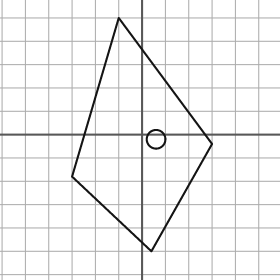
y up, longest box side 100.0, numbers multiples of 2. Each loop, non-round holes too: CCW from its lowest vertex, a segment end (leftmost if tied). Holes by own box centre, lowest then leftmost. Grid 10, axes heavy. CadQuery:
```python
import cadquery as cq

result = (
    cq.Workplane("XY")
    .moveTo(4.0, -50.0)
    .lineTo(30.0, -4.0)
    .lineTo(-10.0, 50.0)
    .lineTo(-30.0, -18.0)
    .close()
    .moveTo(6.0, -2.0)
    .circle(4.0)
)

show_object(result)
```